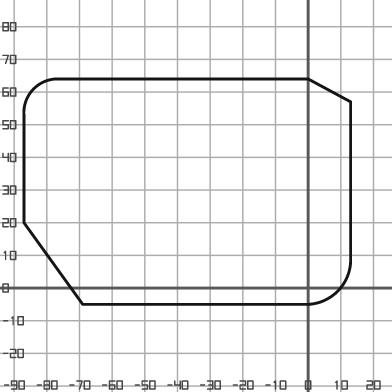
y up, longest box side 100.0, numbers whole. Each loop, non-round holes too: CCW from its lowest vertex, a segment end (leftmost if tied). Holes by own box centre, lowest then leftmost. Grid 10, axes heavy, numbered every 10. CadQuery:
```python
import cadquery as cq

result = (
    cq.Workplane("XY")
    .moveTo(-69.0, -5.0)
    .lineTo(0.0, -5.0)
    .threePointArc((9.0, -1.0), (13.0, 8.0))
    .lineTo(13.0, 57.0)
    .lineTo(0.0, 64.0)
    .lineTo(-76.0, 64.0)
    .threePointArc((-84.0, 61.0), (-87.0, 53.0))
    .lineTo(-87.0, 20.0)
    .close()
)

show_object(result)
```